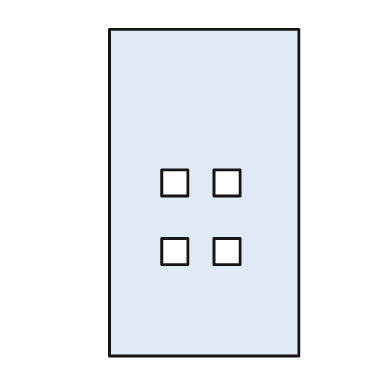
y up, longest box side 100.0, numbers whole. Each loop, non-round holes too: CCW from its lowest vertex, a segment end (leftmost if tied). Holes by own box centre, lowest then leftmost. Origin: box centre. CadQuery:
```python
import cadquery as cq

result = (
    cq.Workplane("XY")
    .moveTo(-29.0, -50.0)
    .lineTo(29.0, -50.0)
    .lineTo(29.0, 50.0)
    .lineTo(-29.0, 50.0)
    .close()
    .moveTo(-13.0, -22.0)
    .lineTo(-5.0, -22.0)
    .lineTo(-5.0, -14.0)
    .lineTo(-13.0, -14.0)
    .close()
    .moveTo(3.0, -22.0)
    .lineTo(11.0, -22.0)
    .lineTo(11.0, -14.0)
    .lineTo(3.0, -14.0)
    .close()
    .moveTo(-13.0, -1.0)
    .lineTo(-5.0, -1.0)
    .lineTo(-5.0, 7.0)
    .lineTo(-13.0, 7.0)
    .close()
    .moveTo(3.0, -1.0)
    .lineTo(11.0, -1.0)
    .lineTo(11.0, 7.0)
    .lineTo(3.0, 7.0)
    .close()
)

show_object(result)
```